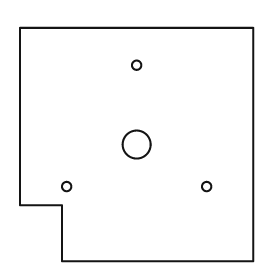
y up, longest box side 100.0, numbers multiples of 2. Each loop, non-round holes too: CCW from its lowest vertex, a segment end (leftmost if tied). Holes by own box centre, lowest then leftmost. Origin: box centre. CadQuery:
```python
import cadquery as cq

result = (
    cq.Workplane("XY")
    .moveTo(-32.0, -50.0)
    .lineTo(50.0, -50.0)
    .lineTo(50.0, 50.0)
    .lineTo(-50.0, 50.0)
    .lineTo(-50.0, -26.0)
    .lineTo(-32.0, -26.0)
    .close()
    .moveTo(-30.0, -18.0)
    .circle(2.0)
    .moveTo(30.0, -18.0)
    .circle(2.0)
    .moveTo(0.0, 0.0)
    .circle(6.0)
    .moveTo(0.0, 34.0)
    .circle(2.0)
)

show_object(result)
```